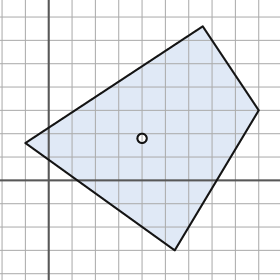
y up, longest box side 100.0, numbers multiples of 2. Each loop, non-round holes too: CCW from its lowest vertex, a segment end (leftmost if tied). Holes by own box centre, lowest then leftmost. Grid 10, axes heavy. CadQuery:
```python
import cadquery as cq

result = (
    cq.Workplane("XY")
    .moveTo(54.0, -30.0)
    .lineTo(90.0, 30.0)
    .lineTo(66.0, 66.0)
    .lineTo(-10.0, 16.0)
    .close()
    .moveTo(40.0, 18.0)
    .circle(2.0)
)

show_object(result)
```